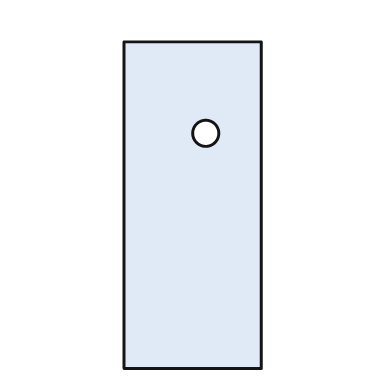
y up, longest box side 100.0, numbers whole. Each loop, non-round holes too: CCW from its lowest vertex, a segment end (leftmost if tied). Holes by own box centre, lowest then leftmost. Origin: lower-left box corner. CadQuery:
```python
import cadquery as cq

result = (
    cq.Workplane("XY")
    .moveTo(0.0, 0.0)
    .lineTo(42.0, 0.0)
    .lineTo(42.0, 100.0)
    .lineTo(0.0, 100.0)
    .close()
    .moveTo(25.0, 72.0)
    .circle(4.0)
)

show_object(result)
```